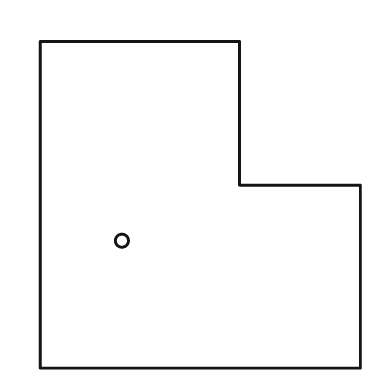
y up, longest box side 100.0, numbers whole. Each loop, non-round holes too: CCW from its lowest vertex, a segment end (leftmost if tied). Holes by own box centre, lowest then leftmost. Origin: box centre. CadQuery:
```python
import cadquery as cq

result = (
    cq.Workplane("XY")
    .moveTo(-49.0, -50.0)
    .lineTo(49.0, -50.0)
    .lineTo(49.0, 6.0)
    .lineTo(12.0, 6.0)
    .lineTo(12.0, 50.0)
    .lineTo(-49.0, 50.0)
    .close()
    .moveTo(-24.0, -11.0)
    .circle(2.0)
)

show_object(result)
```